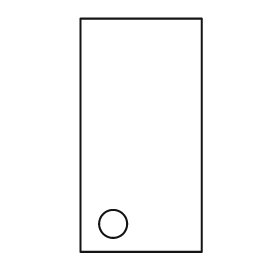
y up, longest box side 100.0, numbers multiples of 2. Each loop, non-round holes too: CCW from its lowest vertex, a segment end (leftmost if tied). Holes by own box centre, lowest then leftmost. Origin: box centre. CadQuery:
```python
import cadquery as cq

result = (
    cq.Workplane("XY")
    .moveTo(-26.0, -50.0)
    .lineTo(26.0, -50.0)
    .lineTo(26.0, 50.0)
    .lineTo(-26.0, 50.0)
    .close()
    .moveTo(-12.0, -38.0)
    .circle(6.0)
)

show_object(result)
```